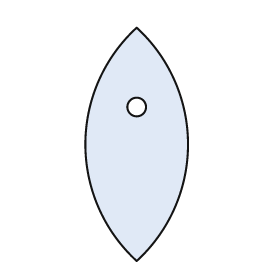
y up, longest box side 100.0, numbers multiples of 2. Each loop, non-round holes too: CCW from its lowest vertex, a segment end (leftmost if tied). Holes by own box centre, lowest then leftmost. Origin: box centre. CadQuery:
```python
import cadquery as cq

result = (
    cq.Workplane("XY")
    .moveTo(0.0, -50.0)
    .threePointArc((22.0, 0.0), (0.0, 50.0))
    .threePointArc((-22.0, 0.0), (0.0, -50.0))
    .close()
    .moveTo(0.0, 16.0)
    .circle(4.0)
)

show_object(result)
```